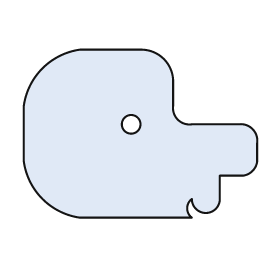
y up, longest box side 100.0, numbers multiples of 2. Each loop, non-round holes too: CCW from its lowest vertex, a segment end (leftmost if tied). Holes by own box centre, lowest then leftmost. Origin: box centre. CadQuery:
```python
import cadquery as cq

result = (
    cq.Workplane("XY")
    .moveTo(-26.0, -36.0)
    .lineTo(22.0, -36.0)
    .threePointArc((20.0, -32.0), (22.0, -28.0))
    .threePointArc((28.0, -34.0), (34.0, -28.0))
    .lineTo(34.0, -18.0)
    .lineTo(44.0, -18.0)
    .threePointArc((48.0, -16.0), (50.0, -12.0))
    .lineTo(50.0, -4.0)
    .threePointArc((48.0, 2.0), (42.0, 4.0))
    .lineTo(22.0, 4.0)
    .threePointArc((16.0, 6.0), (14.0, 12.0))
    .lineTo(14.0, 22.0)
    .threePointArc((10.0, 32.0), (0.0, 36.0))
    .lineTo(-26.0, 36.0)
    .threePointArc((-42.0, 28.0), (-50.0, 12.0))
    .lineTo(-50.0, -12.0)
    .threePointArc((-42.0, -28.0), (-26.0, -36.0))
    .close()
    .moveTo(-4.0, 4.0)
    .circle(4.0)
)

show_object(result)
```